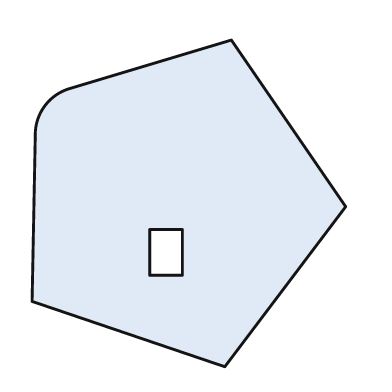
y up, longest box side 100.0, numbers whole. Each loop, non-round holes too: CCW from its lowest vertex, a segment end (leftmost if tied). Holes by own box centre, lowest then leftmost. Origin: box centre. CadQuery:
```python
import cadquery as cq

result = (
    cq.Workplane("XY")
    .moveTo(11.0, -50.0)
    .lineTo(48.0, -1.0)
    .lineTo(13.0, 50.0)
    .lineTo(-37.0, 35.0)
    .threePointArc((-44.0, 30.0), (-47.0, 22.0))
    .lineTo(-48.0, -30.0)
    .close()
    .moveTo(-12.0, -22.0)
    .lineTo(-2.0, -22.0)
    .lineTo(-2.0, -8.0)
    .lineTo(-12.0, -8.0)
    .close()
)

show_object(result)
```